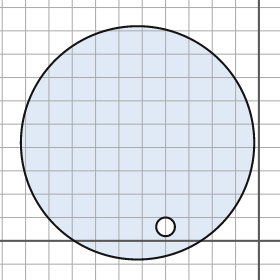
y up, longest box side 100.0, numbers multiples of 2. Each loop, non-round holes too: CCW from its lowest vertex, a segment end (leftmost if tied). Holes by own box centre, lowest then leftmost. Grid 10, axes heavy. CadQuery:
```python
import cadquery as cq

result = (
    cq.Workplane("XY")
    .moveTo(-52.0, 42.0)
    .circle(50.0)
    .moveTo(-40.0, 6.0)
    .circle(4.0)
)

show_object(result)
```